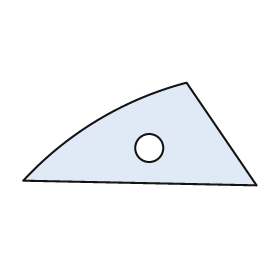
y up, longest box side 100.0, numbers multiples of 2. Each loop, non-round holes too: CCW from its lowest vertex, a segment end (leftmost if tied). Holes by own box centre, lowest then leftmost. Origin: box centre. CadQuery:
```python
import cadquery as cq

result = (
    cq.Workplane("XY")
    .moveTo(50.0, -22.0)
    .lineTo(20.0, 22.0)
    .threePointArc((-18.0, 6.0), (-50.0, -20.0))
    .close()
    .moveTo(4.0, -6.0)
    .circle(6.0)
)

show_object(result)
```